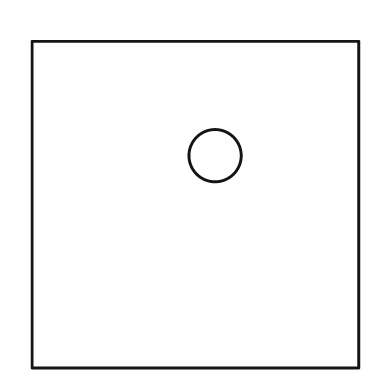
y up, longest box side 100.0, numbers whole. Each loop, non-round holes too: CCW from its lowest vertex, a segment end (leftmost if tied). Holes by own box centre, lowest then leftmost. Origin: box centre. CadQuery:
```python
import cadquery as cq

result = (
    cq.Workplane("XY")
    .moveTo(-50.0, -50.0)
    .lineTo(50.0, -50.0)
    .lineTo(50.0, 50.0)
    .lineTo(-50.0, 50.0)
    .close()
    .moveTo(6.0, 15.0)
    .circle(8.0)
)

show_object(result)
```